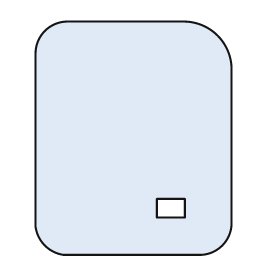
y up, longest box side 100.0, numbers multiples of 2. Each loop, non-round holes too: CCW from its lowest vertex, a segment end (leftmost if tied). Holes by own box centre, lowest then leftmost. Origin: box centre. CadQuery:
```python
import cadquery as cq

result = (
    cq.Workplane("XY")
    .moveTo(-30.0, -50.0)
    .lineTo(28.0, -50.0)
    .threePointArc((38.0, -46.0), (42.0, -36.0))
    .lineTo(42.0, 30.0)
    .threePointArc((36.0, 44.0), (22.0, 50.0))
    .lineTo(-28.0, 50.0)
    .threePointArc((-38.0, 46.0), (-42.0, 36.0))
    .lineTo(-42.0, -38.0)
    .threePointArc((-38.0, -46.0), (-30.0, -50.0))
    .close()
    .moveTo(10.0, -34.0)
    .lineTo(22.0, -34.0)
    .lineTo(22.0, -26.0)
    .lineTo(10.0, -26.0)
    .close()
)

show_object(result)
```